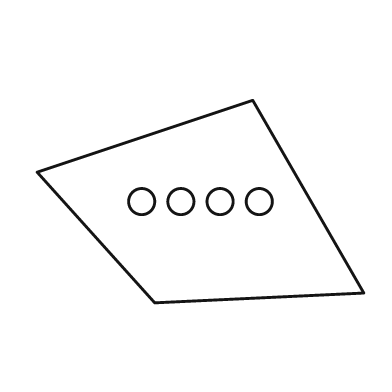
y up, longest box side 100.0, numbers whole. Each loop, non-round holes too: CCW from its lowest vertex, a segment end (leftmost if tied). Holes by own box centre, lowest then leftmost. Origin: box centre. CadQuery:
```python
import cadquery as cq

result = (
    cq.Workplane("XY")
    .moveTo(-14.0, -31.0)
    .lineTo(50.0, -28.0)
    .lineTo(16.0, 31.0)
    .lineTo(-50.0, 9.0)
    .close()
    .moveTo(-18.0, 0.0)
    .circle(4.0)
    .moveTo(-6.0, 0.0)
    .circle(4.0)
    .moveTo(6.0, 0.0)
    .circle(4.0)
    .moveTo(18.0, 0.0)
    .circle(4.0)
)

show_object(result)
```